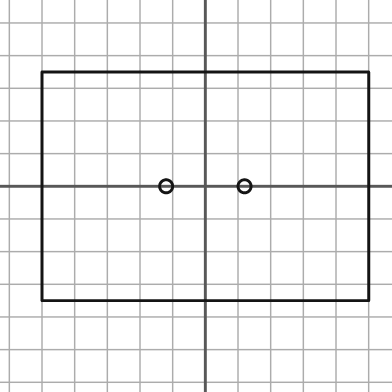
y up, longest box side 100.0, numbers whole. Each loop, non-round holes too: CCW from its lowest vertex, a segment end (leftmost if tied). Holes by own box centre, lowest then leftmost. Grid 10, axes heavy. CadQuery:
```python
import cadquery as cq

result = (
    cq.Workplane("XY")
    .moveTo(-50.0, -35.0)
    .lineTo(50.0, -35.0)
    .lineTo(50.0, 35.0)
    .lineTo(-50.0, 35.0)
    .close()
    .moveTo(-12.0, 0.0)
    .circle(2.0)
    .moveTo(12.0, 0.0)
    .circle(2.0)
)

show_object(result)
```